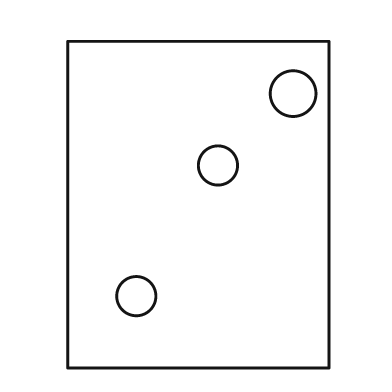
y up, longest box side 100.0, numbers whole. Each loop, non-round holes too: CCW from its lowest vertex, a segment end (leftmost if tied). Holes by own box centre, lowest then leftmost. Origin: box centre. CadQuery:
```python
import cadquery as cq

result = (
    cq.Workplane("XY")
    .moveTo(-40.0, -50.0)
    .lineTo(40.0, -50.0)
    .lineTo(40.0, 50.0)
    .lineTo(-40.0, 50.0)
    .close()
    .moveTo(-19.0, -28.0)
    .circle(6.0)
    .moveTo(6.0, 12.0)
    .circle(6.0)
    .moveTo(29.0, 34.0)
    .circle(7.0)
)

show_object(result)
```